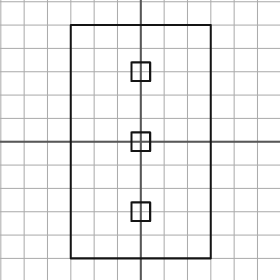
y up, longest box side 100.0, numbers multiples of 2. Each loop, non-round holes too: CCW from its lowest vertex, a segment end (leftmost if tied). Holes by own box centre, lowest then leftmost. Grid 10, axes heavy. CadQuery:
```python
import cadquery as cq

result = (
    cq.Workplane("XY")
    .moveTo(-30.0, -50.0)
    .lineTo(30.0, -50.0)
    .lineTo(30.0, 50.0)
    .lineTo(-30.0, 50.0)
    .close()
    .moveTo(-4.0, -34.0)
    .lineTo(4.0, -34.0)
    .lineTo(4.0, -26.0)
    .lineTo(-4.0, -26.0)
    .close()
    .moveTo(-4.0, -4.0)
    .lineTo(4.0, -4.0)
    .lineTo(4.0, 4.0)
    .lineTo(-4.0, 4.0)
    .close()
    .moveTo(-4.0, 26.0)
    .lineTo(4.0, 26.0)
    .lineTo(4.0, 34.0)
    .lineTo(-4.0, 34.0)
    .close()
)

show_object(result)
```